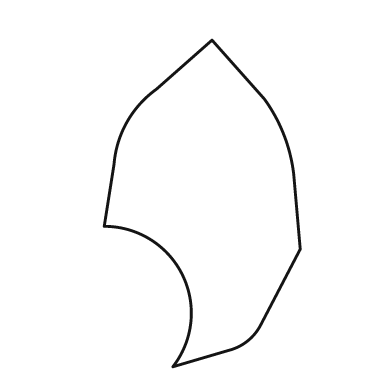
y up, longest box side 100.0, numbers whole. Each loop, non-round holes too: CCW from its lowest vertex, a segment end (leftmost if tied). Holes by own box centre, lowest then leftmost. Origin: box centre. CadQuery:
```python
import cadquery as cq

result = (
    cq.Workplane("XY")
    .moveTo(-9.0, -50.0)
    .lineTo(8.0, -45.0)
    .threePointArc((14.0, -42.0), (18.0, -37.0))
    .lineTo(30.0, -14.0)
    .lineTo(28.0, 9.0)
    .threePointArc((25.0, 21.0), (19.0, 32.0))
    .lineTo(3.0, 50.0)
    .lineTo(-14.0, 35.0)
    .threePointArc((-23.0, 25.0), (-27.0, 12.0))
    .lineTo(-30.0, -7.0)
    .threePointArc((-6.0, -22.0), (-9.0, -50.0))
    .close()
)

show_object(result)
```